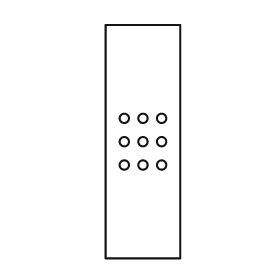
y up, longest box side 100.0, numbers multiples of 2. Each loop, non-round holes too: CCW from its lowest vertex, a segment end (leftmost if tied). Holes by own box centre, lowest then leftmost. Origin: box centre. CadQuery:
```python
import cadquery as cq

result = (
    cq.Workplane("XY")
    .moveTo(-16.0, -50.0)
    .lineTo(16.0, -50.0)
    .lineTo(16.0, 50.0)
    .lineTo(-16.0, 50.0)
    .close()
    .moveTo(-8.0, -10.0)
    .circle(2.0)
    .moveTo(0.0, -10.0)
    .circle(2.0)
    .moveTo(8.0, -10.0)
    .circle(2.0)
    .moveTo(-8.0, 0.0)
    .circle(2.0)
    .moveTo(0.0, 0.0)
    .circle(2.0)
    .moveTo(8.0, 0.0)
    .circle(2.0)
    .moveTo(-8.0, 10.0)
    .circle(2.0)
    .moveTo(0.0, 10.0)
    .circle(2.0)
    .moveTo(8.0, 10.0)
    .circle(2.0)
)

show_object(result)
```